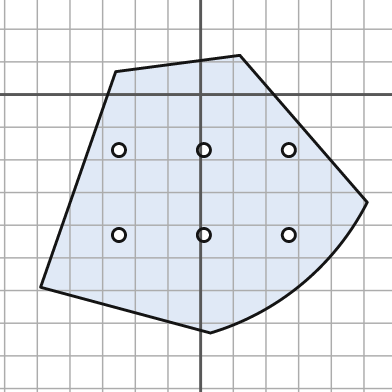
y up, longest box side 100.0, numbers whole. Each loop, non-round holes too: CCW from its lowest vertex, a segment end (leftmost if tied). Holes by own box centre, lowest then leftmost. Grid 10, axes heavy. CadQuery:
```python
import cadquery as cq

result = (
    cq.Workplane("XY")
    .moveTo(3.0, -73.0)
    .threePointArc((31.0, -58.0), (51.0, -33.0))
    .lineTo(12.0, 12.0)
    .lineTo(-26.0, 7.0)
    .lineTo(-49.0, -59.0)
    .close()
    .moveTo(-25.0, -43.0)
    .circle(2.0)
    .moveTo(1.0, -43.0)
    .circle(2.0)
    .moveTo(27.0, -43.0)
    .circle(2.0)
    .moveTo(-25.0, -17.0)
    .circle(2.0)
    .moveTo(1.0, -17.0)
    .circle(2.0)
    .moveTo(27.0, -17.0)
    .circle(2.0)
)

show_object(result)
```